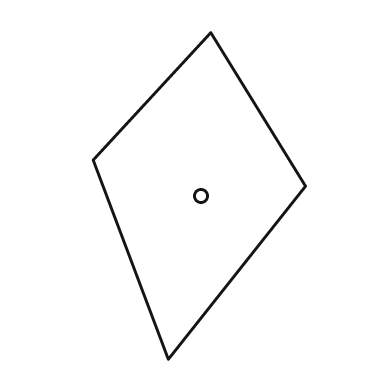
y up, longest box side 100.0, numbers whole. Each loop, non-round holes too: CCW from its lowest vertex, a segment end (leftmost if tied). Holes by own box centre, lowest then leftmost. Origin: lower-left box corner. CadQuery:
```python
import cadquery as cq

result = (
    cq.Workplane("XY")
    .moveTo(23.0, 0.0)
    .lineTo(65.0, 53.0)
    .lineTo(36.0, 100.0)
    .lineTo(0.0, 61.0)
    .close()
    .moveTo(33.0, 50.0)
    .circle(2.0)
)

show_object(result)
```